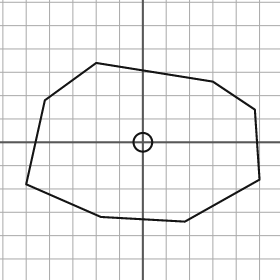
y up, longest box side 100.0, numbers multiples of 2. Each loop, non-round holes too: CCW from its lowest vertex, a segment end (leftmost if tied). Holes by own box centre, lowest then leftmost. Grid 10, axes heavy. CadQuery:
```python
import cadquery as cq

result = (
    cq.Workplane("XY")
    .moveTo(18.0, -34.0)
    .lineTo(50.0, -16.0)
    .lineTo(48.0, 14.0)
    .lineTo(30.0, 26.0)
    .lineTo(-20.0, 34.0)
    .lineTo(-42.0, 18.0)
    .lineTo(-50.0, -18.0)
    .lineTo(-18.0, -32.0)
    .close()
    .moveTo(0.0, 0.0)
    .circle(4.0)
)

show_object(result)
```